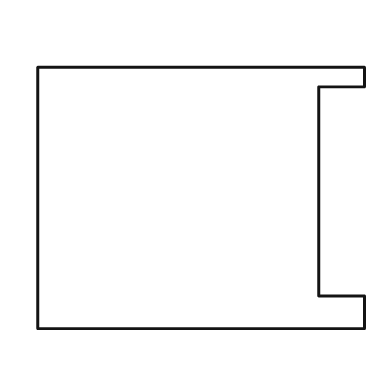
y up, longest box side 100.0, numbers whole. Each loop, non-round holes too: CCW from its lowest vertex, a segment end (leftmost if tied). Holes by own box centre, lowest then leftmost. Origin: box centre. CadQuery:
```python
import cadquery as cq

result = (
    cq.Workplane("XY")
    .moveTo(-50.0, -40.0)
    .lineTo(50.0, -40.0)
    .lineTo(50.0, -30.0)
    .lineTo(36.0, -30.0)
    .lineTo(36.0, 34.0)
    .lineTo(50.0, 34.0)
    .lineTo(50.0, 40.0)
    .lineTo(-50.0, 40.0)
    .close()
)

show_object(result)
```